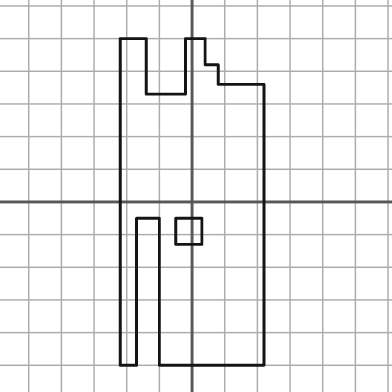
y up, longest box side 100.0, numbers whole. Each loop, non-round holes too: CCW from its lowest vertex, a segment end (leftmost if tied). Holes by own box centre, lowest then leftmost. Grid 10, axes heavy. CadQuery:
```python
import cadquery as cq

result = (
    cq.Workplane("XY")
    .moveTo(-22.0, -50.0)
    .lineTo(-17.0, -50.0)
    .lineTo(-17.0, -5.0)
    .lineTo(-10.0, -5.0)
    .lineTo(-10.0, -50.0)
    .lineTo(22.0, -50.0)
    .lineTo(22.0, 36.0)
    .lineTo(8.0, 36.0)
    .lineTo(8.0, 42.0)
    .lineTo(4.0, 42.0)
    .lineTo(4.0, 50.0)
    .lineTo(-2.0, 50.0)
    .lineTo(-2.0, 33.0)
    .lineTo(-14.0, 33.0)
    .lineTo(-14.0, 50.0)
    .lineTo(-22.0, 50.0)
    .close()
    .moveTo(-5.0, -13.0)
    .lineTo(3.0, -13.0)
    .lineTo(3.0, -5.0)
    .lineTo(-5.0, -5.0)
    .close()
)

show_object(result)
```